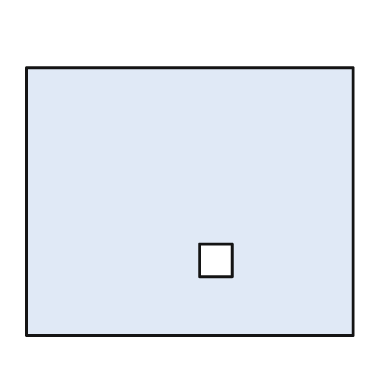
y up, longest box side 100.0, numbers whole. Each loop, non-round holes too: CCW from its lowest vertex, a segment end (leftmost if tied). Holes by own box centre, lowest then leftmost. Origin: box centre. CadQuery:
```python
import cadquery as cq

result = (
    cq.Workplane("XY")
    .moveTo(-50.0, -41.0)
    .lineTo(50.0, -41.0)
    .lineTo(50.0, 41.0)
    .lineTo(-50.0, 41.0)
    .close()
    .moveTo(3.0, -23.0)
    .lineTo(13.0, -23.0)
    .lineTo(13.0, -13.0)
    .lineTo(3.0, -13.0)
    .close()
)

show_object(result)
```